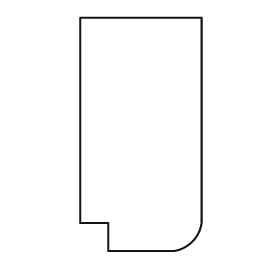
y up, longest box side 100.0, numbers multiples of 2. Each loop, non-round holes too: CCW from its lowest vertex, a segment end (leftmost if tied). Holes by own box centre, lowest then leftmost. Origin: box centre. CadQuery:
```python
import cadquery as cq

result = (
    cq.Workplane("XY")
    .moveTo(-14.0, -50.0)
    .lineTo(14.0, -50.0)
    .threePointArc((22.0, -46.0), (26.0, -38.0))
    .lineTo(26.0, 50.0)
    .lineTo(-26.0, 50.0)
    .lineTo(-26.0, -38.0)
    .lineTo(-14.0, -38.0)
    .close()
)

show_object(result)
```